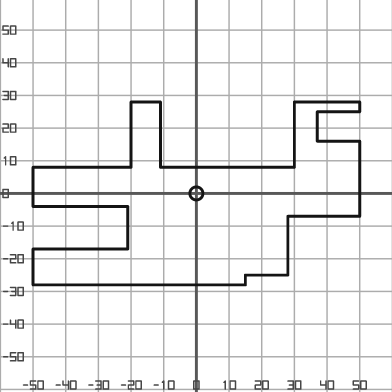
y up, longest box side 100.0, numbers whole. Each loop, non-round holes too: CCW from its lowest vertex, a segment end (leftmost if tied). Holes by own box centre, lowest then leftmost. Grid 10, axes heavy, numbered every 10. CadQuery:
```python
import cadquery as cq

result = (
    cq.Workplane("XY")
    .moveTo(-50.0, -28.0)
    .lineTo(15.0, -28.0)
    .lineTo(15.0, -25.0)
    .lineTo(28.0, -25.0)
    .lineTo(28.0, -7.0)
    .lineTo(50.0, -7.0)
    .lineTo(50.0, 16.0)
    .lineTo(37.0, 16.0)
    .lineTo(37.0, 25.0)
    .lineTo(50.0, 25.0)
    .lineTo(50.0, 28.0)
    .lineTo(30.0, 28.0)
    .lineTo(30.0, 8.0)
    .lineTo(-11.0, 8.0)
    .lineTo(-11.0, 28.0)
    .lineTo(-20.0, 28.0)
    .lineTo(-20.0, 8.0)
    .lineTo(-50.0, 8.0)
    .lineTo(-50.0, -4.0)
    .lineTo(-21.0, -4.0)
    .lineTo(-21.0, -17.0)
    .lineTo(-50.0, -17.0)
    .close()
    .moveTo(0.0, 0.0)
    .circle(2.0)
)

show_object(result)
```